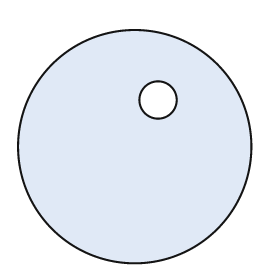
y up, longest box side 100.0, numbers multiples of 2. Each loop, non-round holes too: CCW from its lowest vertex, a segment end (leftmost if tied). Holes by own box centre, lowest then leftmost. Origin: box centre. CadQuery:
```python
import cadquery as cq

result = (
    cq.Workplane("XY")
    .moveTo(0.0, 0.0)
    .circle(50.0)
    .moveTo(10.0, 20.0)
    .circle(8.0)
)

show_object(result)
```